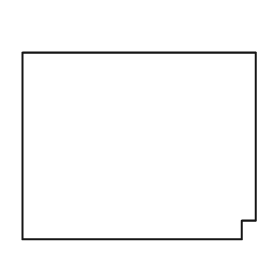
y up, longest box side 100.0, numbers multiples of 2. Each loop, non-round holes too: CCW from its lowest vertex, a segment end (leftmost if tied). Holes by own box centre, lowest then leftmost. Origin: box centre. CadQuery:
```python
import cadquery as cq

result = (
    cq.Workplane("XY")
    .moveTo(-50.0, -40.0)
    .lineTo(44.0, -40.0)
    .lineTo(44.0, -32.0)
    .lineTo(50.0, -32.0)
    .lineTo(50.0, 40.0)
    .lineTo(-50.0, 40.0)
    .close()
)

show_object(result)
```